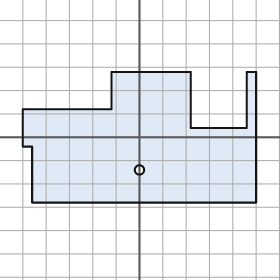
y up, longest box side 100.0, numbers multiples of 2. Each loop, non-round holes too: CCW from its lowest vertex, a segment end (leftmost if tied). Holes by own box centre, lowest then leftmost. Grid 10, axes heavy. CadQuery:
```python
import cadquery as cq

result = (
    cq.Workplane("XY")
    .moveTo(-46.0, -28.0)
    .lineTo(50.0, -28.0)
    .lineTo(50.0, 28.0)
    .lineTo(46.0, 28.0)
    .lineTo(46.0, 4.0)
    .lineTo(22.0, 4.0)
    .lineTo(22.0, 28.0)
    .lineTo(-12.0, 28.0)
    .lineTo(-12.0, 12.0)
    .lineTo(-50.0, 12.0)
    .lineTo(-50.0, -4.0)
    .lineTo(-46.0, -4.0)
    .close()
    .moveTo(0.0, -14.0)
    .circle(2.0)
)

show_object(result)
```